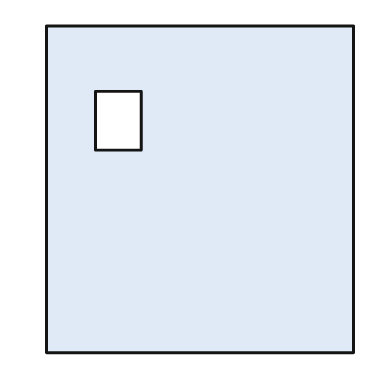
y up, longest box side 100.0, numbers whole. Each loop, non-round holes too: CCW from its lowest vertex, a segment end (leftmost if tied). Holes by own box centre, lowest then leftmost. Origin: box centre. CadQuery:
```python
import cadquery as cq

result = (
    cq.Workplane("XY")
    .moveTo(-47.0, -50.0)
    .lineTo(47.0, -50.0)
    .lineTo(47.0, 50.0)
    .lineTo(-47.0, 50.0)
    .close()
    .moveTo(-32.0, 12.0)
    .lineTo(-18.0, 12.0)
    .lineTo(-18.0, 30.0)
    .lineTo(-32.0, 30.0)
    .close()
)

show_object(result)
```